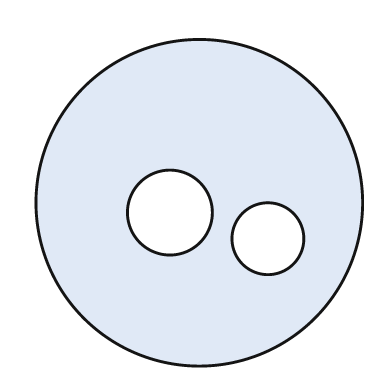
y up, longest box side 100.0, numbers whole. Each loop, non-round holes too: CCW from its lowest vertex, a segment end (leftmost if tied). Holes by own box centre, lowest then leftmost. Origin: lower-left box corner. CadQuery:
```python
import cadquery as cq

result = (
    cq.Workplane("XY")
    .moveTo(50.0, 50.0)
    .circle(50.0)
    .moveTo(71.0, 39.0)
    .circle(11.0)
    .moveTo(41.0, 47.0)
    .circle(13.0)
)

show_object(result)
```